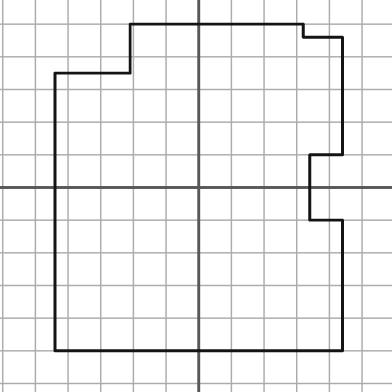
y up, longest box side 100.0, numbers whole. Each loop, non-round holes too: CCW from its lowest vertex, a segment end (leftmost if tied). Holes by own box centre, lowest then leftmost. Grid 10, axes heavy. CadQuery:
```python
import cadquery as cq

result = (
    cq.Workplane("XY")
    .moveTo(-44.0, -50.0)
    .lineTo(44.0, -50.0)
    .lineTo(44.0, -10.0)
    .lineTo(34.0, -10.0)
    .lineTo(34.0, 10.0)
    .lineTo(44.0, 10.0)
    .lineTo(44.0, 46.0)
    .lineTo(32.0, 46.0)
    .lineTo(32.0, 50.0)
    .lineTo(-21.0, 50.0)
    .lineTo(-21.0, 35.0)
    .lineTo(-44.0, 35.0)
    .close()
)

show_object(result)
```